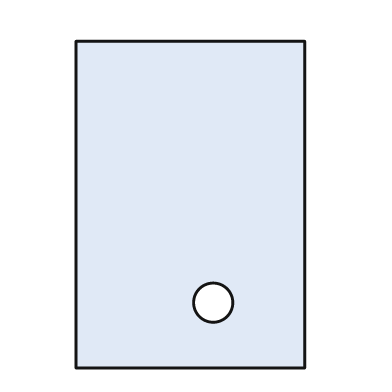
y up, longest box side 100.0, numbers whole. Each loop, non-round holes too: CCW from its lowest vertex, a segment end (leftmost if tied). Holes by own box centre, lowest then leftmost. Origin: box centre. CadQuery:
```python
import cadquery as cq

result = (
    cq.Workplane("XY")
    .moveTo(-35.0, -50.0)
    .lineTo(35.0, -50.0)
    .lineTo(35.0, 50.0)
    .lineTo(-35.0, 50.0)
    .close()
    .moveTo(7.0, -30.0)
    .circle(6.0)
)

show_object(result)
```